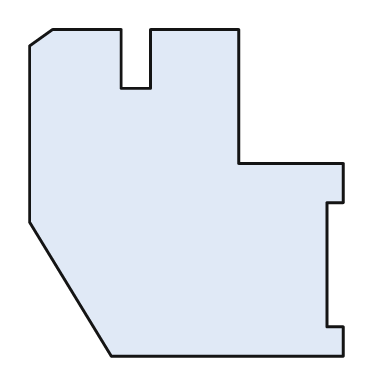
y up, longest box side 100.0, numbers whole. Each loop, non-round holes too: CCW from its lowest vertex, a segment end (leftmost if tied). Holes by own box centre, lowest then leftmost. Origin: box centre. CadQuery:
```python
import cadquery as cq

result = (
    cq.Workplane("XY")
    .moveTo(-23.0, -50.0)
    .lineTo(48.0, -50.0)
    .lineTo(48.0, -41.0)
    .lineTo(43.0, -41.0)
    .lineTo(43.0, -3.0)
    .lineTo(48.0, -3.0)
    .lineTo(48.0, 9.0)
    .lineTo(16.0, 9.0)
    .lineTo(16.0, 50.0)
    .lineTo(-11.0, 50.0)
    .lineTo(-11.0, 32.0)
    .lineTo(-20.0, 32.0)
    .lineTo(-20.0, 50.0)
    .lineTo(-41.0, 50.0)
    .lineTo(-48.0, 45.0)
    .lineTo(-48.0, -9.0)
    .close()
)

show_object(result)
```